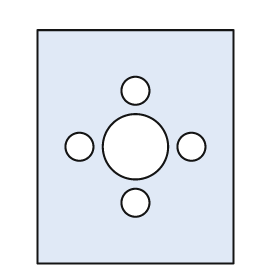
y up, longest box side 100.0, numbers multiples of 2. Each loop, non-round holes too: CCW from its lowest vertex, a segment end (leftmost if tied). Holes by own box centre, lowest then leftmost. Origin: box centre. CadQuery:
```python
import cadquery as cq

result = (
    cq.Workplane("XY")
    .moveTo(-42.0, -50.0)
    .lineTo(42.0, -50.0)
    .lineTo(42.0, 50.0)
    .lineTo(-42.0, 50.0)
    .close()
    .moveTo(0.0, -24.0)
    .circle(6.0)
    .moveTo(-24.0, 0.0)
    .circle(6.0)
    .moveTo(0.0, 0.0)
    .circle(14.0)
    .moveTo(24.0, 0.0)
    .circle(6.0)
    .moveTo(0.0, 24.0)
    .circle(6.0)
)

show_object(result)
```